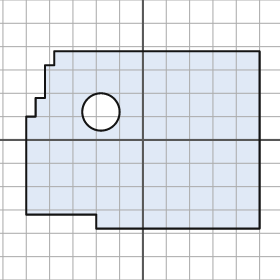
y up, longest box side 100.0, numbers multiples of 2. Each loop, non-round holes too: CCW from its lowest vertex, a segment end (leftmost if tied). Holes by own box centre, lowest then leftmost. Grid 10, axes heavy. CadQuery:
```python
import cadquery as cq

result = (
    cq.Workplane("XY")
    .moveTo(-20.0, -38.0)
    .lineTo(50.0, -38.0)
    .lineTo(50.0, 38.0)
    .lineTo(-38.0, 38.0)
    .lineTo(-38.0, 32.0)
    .lineTo(-42.0, 32.0)
    .lineTo(-42.0, 18.0)
    .lineTo(-46.0, 18.0)
    .lineTo(-46.0, 10.0)
    .lineTo(-50.0, 10.0)
    .lineTo(-50.0, -32.0)
    .lineTo(-20.0, -32.0)
    .close()
    .moveTo(-18.0, 12.0)
    .circle(8.0)
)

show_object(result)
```